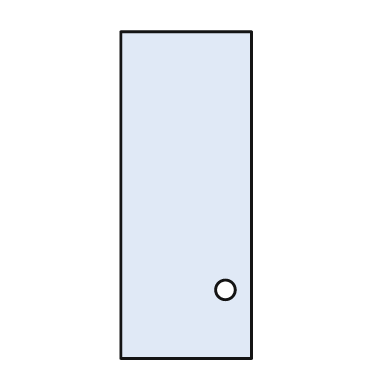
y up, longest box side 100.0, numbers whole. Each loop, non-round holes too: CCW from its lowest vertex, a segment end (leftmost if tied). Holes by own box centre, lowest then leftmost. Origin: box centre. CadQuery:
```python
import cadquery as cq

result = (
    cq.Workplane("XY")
    .moveTo(-20.0, -50.0)
    .lineTo(20.0, -50.0)
    .lineTo(20.0, 50.0)
    .lineTo(-20.0, 50.0)
    .close()
    .moveTo(12.0, -29.0)
    .circle(3.0)
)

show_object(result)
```